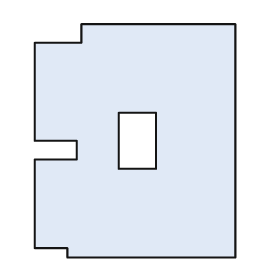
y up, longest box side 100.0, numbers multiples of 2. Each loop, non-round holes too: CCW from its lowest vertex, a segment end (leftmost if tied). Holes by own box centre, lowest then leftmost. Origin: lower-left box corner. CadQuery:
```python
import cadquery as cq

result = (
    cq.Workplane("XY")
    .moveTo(14.0, 0.0)
    .lineTo(86.0, 0.0)
    .lineTo(86.0, 100.0)
    .lineTo(20.0, 100.0)
    .lineTo(20.0, 92.0)
    .lineTo(0.0, 92.0)
    .lineTo(0.0, 50.0)
    .lineTo(18.0, 50.0)
    .lineTo(18.0, 42.0)
    .lineTo(0.0, 42.0)
    .lineTo(0.0, 4.0)
    .lineTo(14.0, 4.0)
    .close()
    .moveTo(36.0, 38.0)
    .lineTo(52.0, 38.0)
    .lineTo(52.0, 62.0)
    .lineTo(36.0, 62.0)
    .close()
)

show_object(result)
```